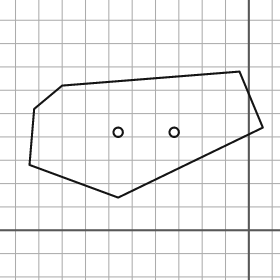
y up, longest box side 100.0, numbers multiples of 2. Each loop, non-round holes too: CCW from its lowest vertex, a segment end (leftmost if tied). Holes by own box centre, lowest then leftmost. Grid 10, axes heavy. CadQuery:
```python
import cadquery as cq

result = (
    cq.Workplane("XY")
    .moveTo(-56.0, 14.0)
    .lineTo(6.0, 44.0)
    .lineTo(-4.0, 68.0)
    .lineTo(-80.0, 62.0)
    .lineTo(-92.0, 52.0)
    .lineTo(-94.0, 28.0)
    .close()
    .moveTo(-56.0, 42.0)
    .circle(2.0)
    .moveTo(-32.0, 42.0)
    .circle(2.0)
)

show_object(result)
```